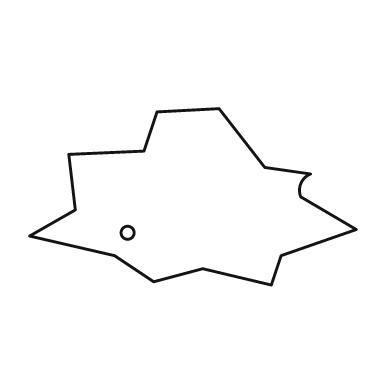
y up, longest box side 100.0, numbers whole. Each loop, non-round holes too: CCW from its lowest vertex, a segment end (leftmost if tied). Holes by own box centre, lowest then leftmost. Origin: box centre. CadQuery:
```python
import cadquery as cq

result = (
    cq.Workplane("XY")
    .moveTo(24.0, -27.0)
    .lineTo(27.0, -18.0)
    .lineTo(50.0, -10.0)
    .lineTo(33.0, 0.0)
    .threePointArc((33.0, 4.0), (36.0, 7.0))
    .lineTo(22.0, 9.0)
    .lineTo(8.0, 27.0)
    .lineTo(-11.0, 26.0)
    .lineTo(-15.0, 14.0)
    .lineTo(-38.0, 13.0)
    .lineTo(-36.0, -4.0)
    .lineTo(-50.0, -12.0)
    .lineTo(-24.0, -18.0)
    .lineTo(-12.0, -26.0)
    .lineTo(3.0, -22.0)
    .close()
    .moveTo(-20.0, -11.0)
    .circle(2.0)
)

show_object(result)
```